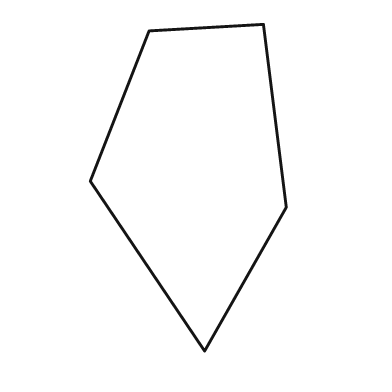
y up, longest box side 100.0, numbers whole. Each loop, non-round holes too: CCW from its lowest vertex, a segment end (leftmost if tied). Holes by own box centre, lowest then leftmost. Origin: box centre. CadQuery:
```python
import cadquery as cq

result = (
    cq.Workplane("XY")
    .moveTo(5.0, -50.0)
    .lineTo(30.0, -6.0)
    .lineTo(23.0, 50.0)
    .lineTo(-12.0, 48.0)
    .lineTo(-30.0, 2.0)
    .close()
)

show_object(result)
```